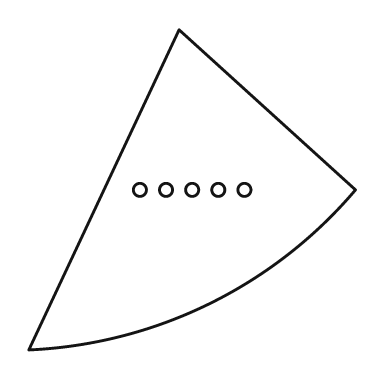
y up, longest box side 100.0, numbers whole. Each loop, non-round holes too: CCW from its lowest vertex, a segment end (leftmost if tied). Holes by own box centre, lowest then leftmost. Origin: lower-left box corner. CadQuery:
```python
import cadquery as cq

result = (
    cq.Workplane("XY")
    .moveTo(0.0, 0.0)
    .threePointArc((55.0, 14.0), (100.0, 49.0))
    .lineTo(46.0, 98.0)
    .close()
    .moveTo(34.0, 49.0)
    .circle(2.0)
    .moveTo(42.0, 49.0)
    .circle(2.0)
    .moveTo(50.0, 49.0)
    .circle(2.0)
    .moveTo(58.0, 49.0)
    .circle(2.0)
    .moveTo(66.0, 49.0)
    .circle(2.0)
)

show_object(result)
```